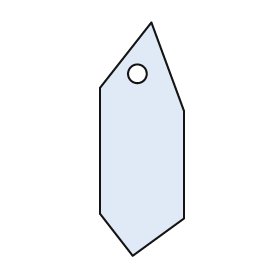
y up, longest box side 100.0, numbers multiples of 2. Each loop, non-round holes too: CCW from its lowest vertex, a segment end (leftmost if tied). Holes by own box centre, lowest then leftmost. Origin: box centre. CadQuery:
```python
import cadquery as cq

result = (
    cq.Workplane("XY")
    .moveTo(-4.0, -50.0)
    .lineTo(18.0, -34.0)
    .lineTo(18.0, 12.0)
    .lineTo(4.0, 50.0)
    .lineTo(-18.0, 22.0)
    .lineTo(-18.0, -32.0)
    .close()
    .moveTo(-2.0, 28.0)
    .circle(4.0)
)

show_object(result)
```